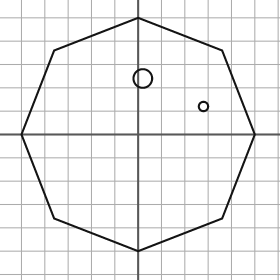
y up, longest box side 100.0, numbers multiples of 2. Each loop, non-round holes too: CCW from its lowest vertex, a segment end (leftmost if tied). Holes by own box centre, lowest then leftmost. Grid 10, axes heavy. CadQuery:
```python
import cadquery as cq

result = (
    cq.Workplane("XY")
    .moveTo(0.0, -50.0)
    .lineTo(36.0, -36.0)
    .lineTo(50.0, 0.0)
    .lineTo(36.0, 36.0)
    .lineTo(0.0, 50.0)
    .lineTo(-36.0, 36.0)
    .lineTo(-50.0, 0.0)
    .lineTo(-36.0, -36.0)
    .close()
    .moveTo(28.0, 12.0)
    .circle(2.0)
    .moveTo(2.0, 24.0)
    .circle(4.0)
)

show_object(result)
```